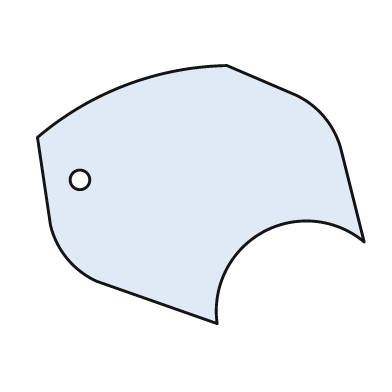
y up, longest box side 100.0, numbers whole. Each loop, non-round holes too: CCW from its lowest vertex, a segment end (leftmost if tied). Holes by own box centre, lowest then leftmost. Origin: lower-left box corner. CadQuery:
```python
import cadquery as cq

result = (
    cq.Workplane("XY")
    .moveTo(55.0, 0.0)
    .threePointArc((69.0, 28.0), (100.0, 25.0))
    .lineTo(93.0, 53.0)
    .threePointArc((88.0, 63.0), (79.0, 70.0))
    .lineTo(58.0, 79.0)
    .threePointArc((27.0, 73.0), (0.0, 57.0))
    .lineTo(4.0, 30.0)
    .threePointArc((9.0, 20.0), (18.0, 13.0))
    .close()
    .moveTo(13.0, 44.0)
    .circle(3.0)
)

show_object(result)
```